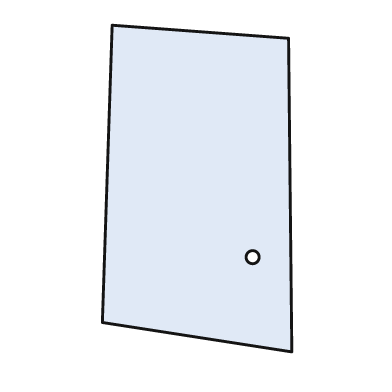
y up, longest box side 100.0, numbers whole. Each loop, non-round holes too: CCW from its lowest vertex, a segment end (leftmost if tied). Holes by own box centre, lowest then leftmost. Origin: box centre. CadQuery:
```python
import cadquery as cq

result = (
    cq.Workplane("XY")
    .moveTo(29.0, -50.0)
    .lineTo(28.0, 46.0)
    .lineTo(-26.0, 50.0)
    .lineTo(-29.0, -41.0)
    .close()
    .moveTo(17.0, -21.0)
    .circle(2.0)
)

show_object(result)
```